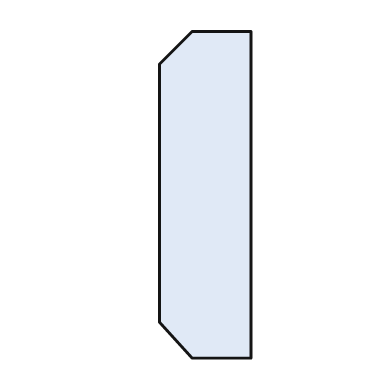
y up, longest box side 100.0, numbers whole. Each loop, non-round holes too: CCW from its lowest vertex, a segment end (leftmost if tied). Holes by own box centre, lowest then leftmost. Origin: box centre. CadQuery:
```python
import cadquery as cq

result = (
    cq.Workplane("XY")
    .moveTo(-4.0, -50.0)
    .lineTo(14.0, -50.0)
    .lineTo(14.0, 50.0)
    .lineTo(-4.0, 50.0)
    .lineTo(-14.0, 40.0)
    .lineTo(-14.0, -39.0)
    .close()
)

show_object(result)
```